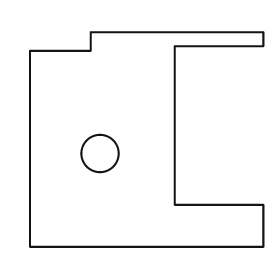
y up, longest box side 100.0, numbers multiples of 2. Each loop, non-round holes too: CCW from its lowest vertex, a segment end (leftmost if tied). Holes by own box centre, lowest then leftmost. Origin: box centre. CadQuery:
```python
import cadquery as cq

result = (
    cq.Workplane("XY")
    .moveTo(-50.0, -46.0)
    .lineTo(50.0, -46.0)
    .lineTo(50.0, -28.0)
    .lineTo(12.0, -28.0)
    .lineTo(12.0, 40.0)
    .lineTo(50.0, 40.0)
    .lineTo(50.0, 46.0)
    .lineTo(-24.0, 46.0)
    .lineTo(-24.0, 38.0)
    .lineTo(-50.0, 38.0)
    .close()
    .moveTo(-20.0, -6.0)
    .circle(8.0)
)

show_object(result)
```